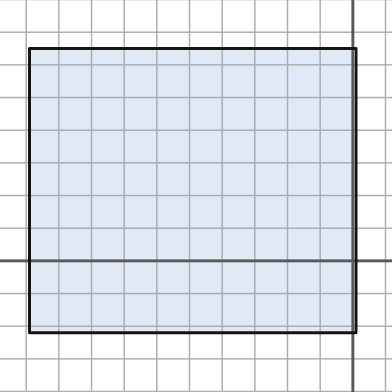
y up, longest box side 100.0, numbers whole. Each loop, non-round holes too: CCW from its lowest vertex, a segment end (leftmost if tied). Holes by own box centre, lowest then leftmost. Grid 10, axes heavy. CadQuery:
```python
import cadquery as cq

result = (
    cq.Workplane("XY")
    .moveTo(-99.0, -22.0)
    .lineTo(1.0, -22.0)
    .lineTo(1.0, 65.0)
    .lineTo(-99.0, 65.0)
    .close()
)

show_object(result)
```